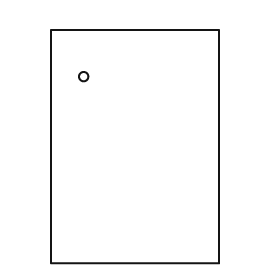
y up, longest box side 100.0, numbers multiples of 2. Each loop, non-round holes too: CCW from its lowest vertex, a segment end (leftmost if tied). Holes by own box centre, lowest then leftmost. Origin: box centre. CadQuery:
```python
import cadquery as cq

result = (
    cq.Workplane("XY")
    .moveTo(-36.0, -50.0)
    .lineTo(36.0, -50.0)
    .lineTo(36.0, 50.0)
    .lineTo(-36.0, 50.0)
    .close()
    .moveTo(-22.0, 30.0)
    .circle(2.0)
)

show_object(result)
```